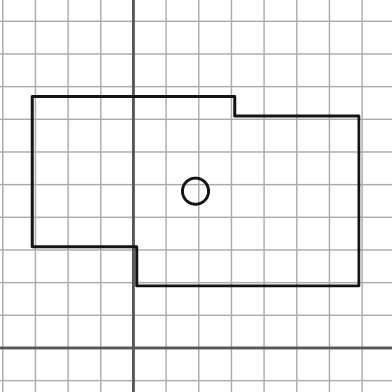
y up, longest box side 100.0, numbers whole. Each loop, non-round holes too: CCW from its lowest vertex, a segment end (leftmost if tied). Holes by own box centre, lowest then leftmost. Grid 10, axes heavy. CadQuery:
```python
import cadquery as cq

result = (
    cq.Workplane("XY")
    .moveTo(1.0, 19.0)
    .lineTo(69.0, 19.0)
    .lineTo(69.0, 71.0)
    .lineTo(31.0, 71.0)
    .lineTo(31.0, 77.0)
    .lineTo(-31.0, 77.0)
    .lineTo(-31.0, 31.0)
    .lineTo(1.0, 31.0)
    .close()
    .moveTo(19.0, 48.0)
    .circle(4.0)
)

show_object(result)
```